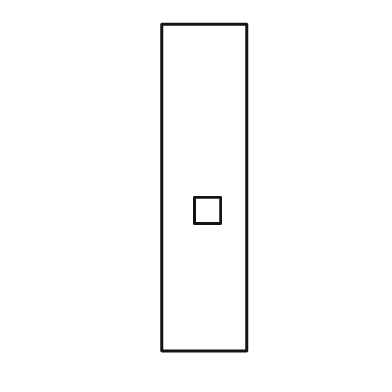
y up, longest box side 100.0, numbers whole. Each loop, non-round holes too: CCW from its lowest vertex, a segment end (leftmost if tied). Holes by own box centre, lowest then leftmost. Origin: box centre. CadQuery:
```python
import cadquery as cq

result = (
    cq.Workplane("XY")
    .moveTo(-13.0, -50.0)
    .lineTo(13.0, -50.0)
    .lineTo(13.0, 50.0)
    .lineTo(-13.0, 50.0)
    .close()
    .moveTo(-3.0, -11.0)
    .lineTo(5.0, -11.0)
    .lineTo(5.0, -3.0)
    .lineTo(-3.0, -3.0)
    .close()
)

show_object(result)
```